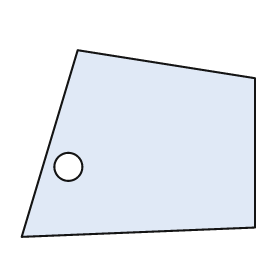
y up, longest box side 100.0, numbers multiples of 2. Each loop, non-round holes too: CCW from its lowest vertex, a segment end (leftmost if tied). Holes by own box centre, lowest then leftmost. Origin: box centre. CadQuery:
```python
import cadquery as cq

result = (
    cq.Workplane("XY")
    .moveTo(-50.0, -40.0)
    .lineTo(50.0, -36.0)
    .lineTo(50.0, 28.0)
    .lineTo(-26.0, 40.0)
    .close()
    .moveTo(-30.0, -10.0)
    .circle(6.0)
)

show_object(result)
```